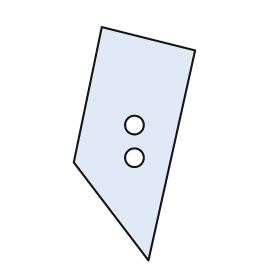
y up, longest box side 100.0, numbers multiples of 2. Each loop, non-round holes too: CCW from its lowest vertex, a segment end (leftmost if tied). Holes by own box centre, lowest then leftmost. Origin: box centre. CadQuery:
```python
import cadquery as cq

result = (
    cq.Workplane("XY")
    .moveTo(6.0, -50.0)
    .lineTo(26.0, 40.0)
    .lineTo(-14.0, 50.0)
    .lineTo(-26.0, -8.0)
    .close()
    .moveTo(0.0, -6.0)
    .circle(4.0)
    .moveTo(0.0, 8.0)
    .circle(4.0)
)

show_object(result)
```